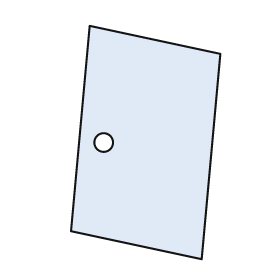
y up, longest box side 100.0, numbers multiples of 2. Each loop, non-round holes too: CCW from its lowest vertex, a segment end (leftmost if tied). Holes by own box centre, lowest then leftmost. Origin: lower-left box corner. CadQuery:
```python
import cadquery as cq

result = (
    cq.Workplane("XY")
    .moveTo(56.0, 0.0)
    .lineTo(64.0, 88.0)
    .lineTo(8.0, 100.0)
    .lineTo(0.0, 12.0)
    .close()
    .moveTo(14.0, 50.0)
    .circle(4.0)
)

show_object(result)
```